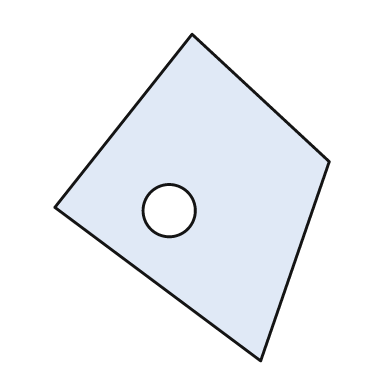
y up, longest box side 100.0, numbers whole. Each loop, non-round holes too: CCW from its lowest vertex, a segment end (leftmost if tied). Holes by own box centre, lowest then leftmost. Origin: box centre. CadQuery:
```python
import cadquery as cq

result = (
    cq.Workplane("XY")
    .moveTo(21.0, -50.0)
    .lineTo(42.0, 11.0)
    .lineTo(0.0, 50.0)
    .lineTo(-42.0, -3.0)
    .close()
    .moveTo(-7.0, -4.0)
    .circle(8.0)
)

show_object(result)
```